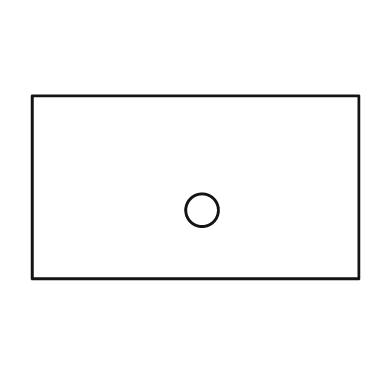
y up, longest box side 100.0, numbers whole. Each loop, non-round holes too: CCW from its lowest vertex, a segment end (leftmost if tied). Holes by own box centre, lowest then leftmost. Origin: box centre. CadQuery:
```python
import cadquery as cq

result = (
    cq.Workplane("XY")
    .moveTo(-50.0, -28.0)
    .lineTo(50.0, -28.0)
    .lineTo(50.0, 28.0)
    .lineTo(-50.0, 28.0)
    .close()
    .moveTo(2.0, -7.0)
    .circle(5.0)
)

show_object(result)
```